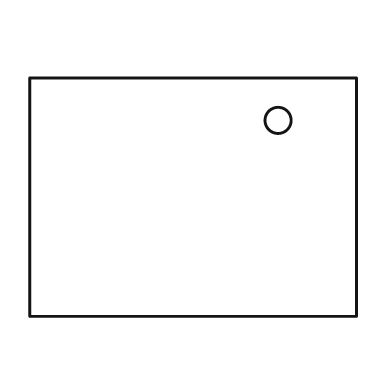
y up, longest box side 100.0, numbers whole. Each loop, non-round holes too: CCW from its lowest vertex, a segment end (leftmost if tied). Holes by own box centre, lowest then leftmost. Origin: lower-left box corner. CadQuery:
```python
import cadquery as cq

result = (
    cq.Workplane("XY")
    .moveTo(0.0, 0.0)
    .lineTo(100.0, 0.0)
    .lineTo(100.0, 73.0)
    .lineTo(0.0, 73.0)
    .close()
    .moveTo(76.0, 60.0)
    .circle(4.0)
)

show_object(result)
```